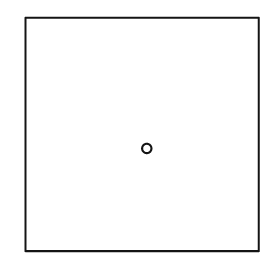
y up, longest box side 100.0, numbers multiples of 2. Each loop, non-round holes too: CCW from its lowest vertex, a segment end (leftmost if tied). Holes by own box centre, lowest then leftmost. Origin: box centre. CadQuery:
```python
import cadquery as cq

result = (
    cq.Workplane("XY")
    .moveTo(-50.0, -50.0)
    .lineTo(50.0, -50.0)
    .lineTo(50.0, 50.0)
    .lineTo(-50.0, 50.0)
    .close()
    .moveTo(2.0, -6.0)
    .circle(2.0)
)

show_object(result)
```